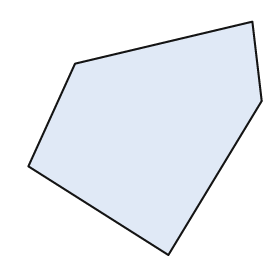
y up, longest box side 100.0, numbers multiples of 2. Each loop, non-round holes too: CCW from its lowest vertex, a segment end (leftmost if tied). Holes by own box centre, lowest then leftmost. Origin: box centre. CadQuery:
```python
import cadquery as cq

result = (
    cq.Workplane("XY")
    .moveTo(10.0, -50.0)
    .lineTo(50.0, 16.0)
    .lineTo(46.0, 50.0)
    .lineTo(-30.0, 32.0)
    .lineTo(-50.0, -12.0)
    .close()
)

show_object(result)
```